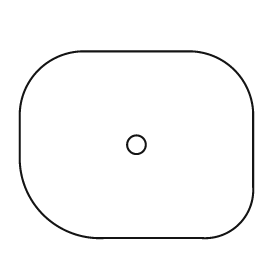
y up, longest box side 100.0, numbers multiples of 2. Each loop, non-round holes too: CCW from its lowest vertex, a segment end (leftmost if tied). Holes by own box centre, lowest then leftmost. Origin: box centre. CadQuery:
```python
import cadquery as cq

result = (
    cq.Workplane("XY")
    .moveTo(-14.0, -40.0)
    .lineTo(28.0, -40.0)
    .threePointArc((44.0, -34.0), (50.0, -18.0))
    .lineTo(50.0, 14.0)
    .threePointArc((42.0, 32.0), (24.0, 40.0))
    .lineTo(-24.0, 40.0)
    .threePointArc((-42.0, 32.0), (-50.0, 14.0))
    .lineTo(-50.0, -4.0)
    .threePointArc((-40.0, -30.0), (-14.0, -40.0))
    .close()
    .moveTo(0.0, 0.0)
    .circle(4.0)
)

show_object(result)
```